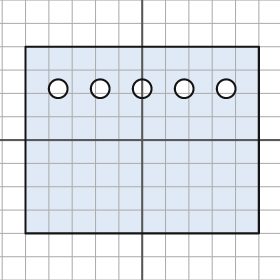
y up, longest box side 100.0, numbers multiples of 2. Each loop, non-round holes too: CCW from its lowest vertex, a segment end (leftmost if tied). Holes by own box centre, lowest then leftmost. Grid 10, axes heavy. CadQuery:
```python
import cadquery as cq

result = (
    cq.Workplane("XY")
    .moveTo(-50.0, -40.0)
    .lineTo(50.0, -40.0)
    .lineTo(50.0, 40.0)
    .lineTo(-50.0, 40.0)
    .close()
    .moveTo(-36.0, 22.0)
    .circle(4.0)
    .moveTo(-18.0, 22.0)
    .circle(4.0)
    .moveTo(0.0, 22.0)
    .circle(4.0)
    .moveTo(18.0, 22.0)
    .circle(4.0)
    .moveTo(36.0, 22.0)
    .circle(4.0)
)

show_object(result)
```